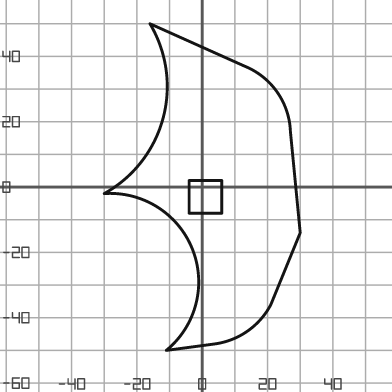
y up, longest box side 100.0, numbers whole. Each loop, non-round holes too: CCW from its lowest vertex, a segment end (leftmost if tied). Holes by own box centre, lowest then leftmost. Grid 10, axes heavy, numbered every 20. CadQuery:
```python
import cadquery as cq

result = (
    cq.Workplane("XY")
    .moveTo(-11.0, -50.0)
    .lineTo(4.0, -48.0)
    .threePointArc((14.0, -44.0), (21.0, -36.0))
    .lineTo(30.0, -14.0)
    .lineTo(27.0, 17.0)
    .threePointArc((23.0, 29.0), (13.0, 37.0))
    .lineTo(-16.0, 50.0)
    .threePointArc((-12.0, 21.0), (-30.0, -2.0))
    .threePointArc((-3.0, -19.0), (-11.0, -50.0))
    .close()
    .moveTo(-4.0, -8.0)
    .lineTo(6.0, -8.0)
    .lineTo(6.0, 2.0)
    .lineTo(-4.0, 2.0)
    .close()
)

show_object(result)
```